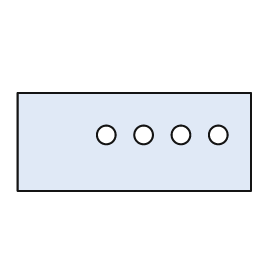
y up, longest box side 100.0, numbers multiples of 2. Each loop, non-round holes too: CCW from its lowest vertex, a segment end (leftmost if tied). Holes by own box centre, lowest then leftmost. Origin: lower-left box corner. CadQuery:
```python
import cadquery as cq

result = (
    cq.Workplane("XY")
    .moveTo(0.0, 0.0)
    .lineTo(100.0, 0.0)
    .lineTo(100.0, 42.0)
    .lineTo(0.0, 42.0)
    .close()
    .moveTo(38.0, 24.0)
    .circle(4.0)
    .moveTo(54.0, 24.0)
    .circle(4.0)
    .moveTo(70.0, 24.0)
    .circle(4.0)
    .moveTo(86.0, 24.0)
    .circle(4.0)
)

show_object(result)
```